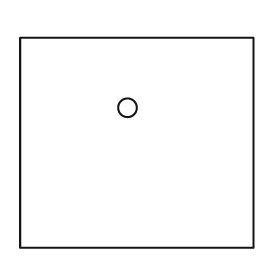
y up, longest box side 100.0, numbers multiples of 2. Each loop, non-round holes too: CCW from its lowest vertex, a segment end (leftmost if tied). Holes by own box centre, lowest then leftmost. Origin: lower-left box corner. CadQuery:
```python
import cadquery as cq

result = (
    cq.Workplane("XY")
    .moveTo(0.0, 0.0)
    .lineTo(100.0, 0.0)
    .lineTo(100.0, 90.0)
    .lineTo(0.0, 90.0)
    .close()
    .moveTo(46.0, 60.0)
    .circle(4.0)
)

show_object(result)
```